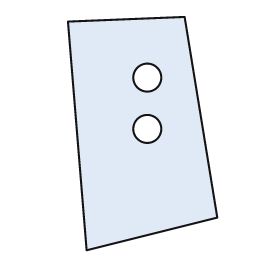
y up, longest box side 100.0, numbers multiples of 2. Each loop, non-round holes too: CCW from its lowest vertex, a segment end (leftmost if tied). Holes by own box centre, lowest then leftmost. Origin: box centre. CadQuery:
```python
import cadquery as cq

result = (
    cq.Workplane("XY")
    .moveTo(-24.0, -50.0)
    .lineTo(32.0, -36.0)
    .lineTo(18.0, 50.0)
    .lineTo(-32.0, 48.0)
    .close()
    .moveTo(2.0, 2.0)
    .circle(6.0)
    .moveTo(2.0, 24.0)
    .circle(6.0)
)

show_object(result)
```